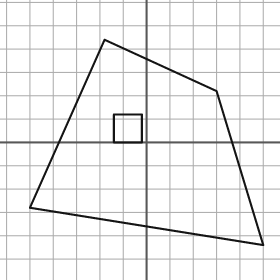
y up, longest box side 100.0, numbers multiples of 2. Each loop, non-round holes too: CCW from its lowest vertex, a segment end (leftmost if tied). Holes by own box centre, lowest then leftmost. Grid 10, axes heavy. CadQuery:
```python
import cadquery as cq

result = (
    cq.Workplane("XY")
    .moveTo(50.0, -44.0)
    .lineTo(30.0, 22.0)
    .lineTo(-18.0, 44.0)
    .lineTo(-50.0, -28.0)
    .close()
    .moveTo(-14.0, 0.0)
    .lineTo(-2.0, 0.0)
    .lineTo(-2.0, 12.0)
    .lineTo(-14.0, 12.0)
    .close()
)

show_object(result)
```